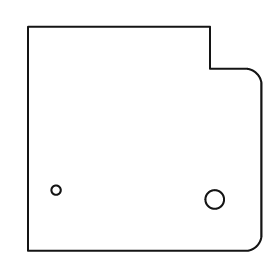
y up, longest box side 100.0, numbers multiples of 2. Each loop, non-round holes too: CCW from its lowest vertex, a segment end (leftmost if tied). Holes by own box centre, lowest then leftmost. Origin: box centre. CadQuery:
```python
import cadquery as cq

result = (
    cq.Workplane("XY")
    .moveTo(-50.0, -48.0)
    .lineTo(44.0, -48.0)
    .threePointArc((48.0, -46.0), (50.0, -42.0))
    .lineTo(50.0, 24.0)
    .threePointArc((48.0, 28.0), (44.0, 30.0))
    .lineTo(28.0, 30.0)
    .lineTo(28.0, 48.0)
    .lineTo(-50.0, 48.0)
    .close()
    .moveTo(30.0, -26.0)
    .circle(4.0)
    .moveTo(-38.0, -22.0)
    .circle(2.0)
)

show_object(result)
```